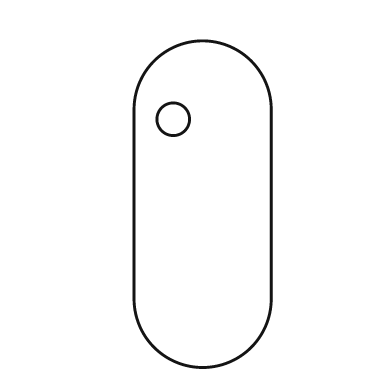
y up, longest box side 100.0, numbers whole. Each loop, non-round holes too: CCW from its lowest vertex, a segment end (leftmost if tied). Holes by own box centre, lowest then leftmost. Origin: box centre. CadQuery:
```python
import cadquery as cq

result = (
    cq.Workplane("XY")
    .moveTo(-21.0, -29.0)
    .threePointArc((0.0, -50.0), (21.0, -29.0))
    .lineTo(21.0, 29.0)
    .threePointArc((0.0, 50.0), (-21.0, 29.0))
    .close()
    .moveTo(-9.0, 26.0)
    .circle(5.0)
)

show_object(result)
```